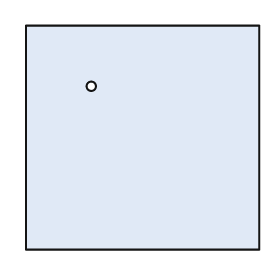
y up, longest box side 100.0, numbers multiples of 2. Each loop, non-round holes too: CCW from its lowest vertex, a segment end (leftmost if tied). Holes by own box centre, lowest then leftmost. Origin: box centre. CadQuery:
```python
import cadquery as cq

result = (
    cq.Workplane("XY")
    .moveTo(-50.0, -48.0)
    .lineTo(50.0, -48.0)
    .lineTo(50.0, 48.0)
    .lineTo(-50.0, 48.0)
    .close()
    .moveTo(-22.0, 22.0)
    .circle(2.0)
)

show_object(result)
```